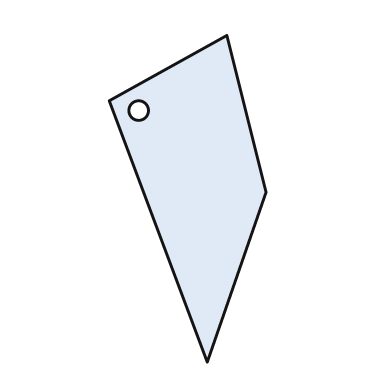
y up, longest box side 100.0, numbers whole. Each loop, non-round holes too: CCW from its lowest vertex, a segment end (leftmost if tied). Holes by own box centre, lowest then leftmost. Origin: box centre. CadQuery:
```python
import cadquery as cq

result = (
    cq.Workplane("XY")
    .moveTo(6.0, -50.0)
    .lineTo(24.0, 2.0)
    .lineTo(12.0, 50.0)
    .lineTo(-24.0, 30.0)
    .close()
    .moveTo(-15.0, 27.0)
    .circle(3.0)
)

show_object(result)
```